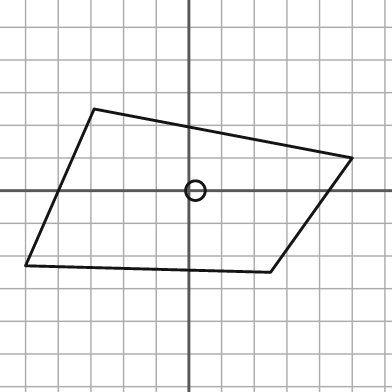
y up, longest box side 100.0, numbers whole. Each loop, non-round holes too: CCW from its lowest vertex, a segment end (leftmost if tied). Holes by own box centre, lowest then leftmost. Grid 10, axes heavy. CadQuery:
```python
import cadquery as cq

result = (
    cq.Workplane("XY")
    .moveTo(25.0, -25.0)
    .lineTo(50.0, 10.0)
    .lineTo(-29.0, 25.0)
    .lineTo(-50.0, -23.0)
    .close()
    .moveTo(2.0, 0.0)
    .circle(3.0)
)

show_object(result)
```